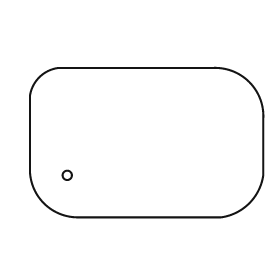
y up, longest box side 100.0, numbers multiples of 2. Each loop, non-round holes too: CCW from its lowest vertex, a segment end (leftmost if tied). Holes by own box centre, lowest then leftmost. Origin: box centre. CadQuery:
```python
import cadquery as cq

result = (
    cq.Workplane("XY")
    .moveTo(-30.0, -32.0)
    .lineTo(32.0, -32.0)
    .threePointArc((44.0, -26.0), (50.0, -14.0))
    .lineTo(50.0, 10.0)
    .threePointArc((44.0, 26.0), (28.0, 32.0))
    .lineTo(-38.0, 32.0)
    .threePointArc((-46.0, 28.0), (-50.0, 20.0))
    .lineTo(-50.0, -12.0)
    .threePointArc((-44.0, -26.0), (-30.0, -32.0))
    .close()
    .moveTo(-34.0, -14.0)
    .circle(2.0)
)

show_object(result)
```